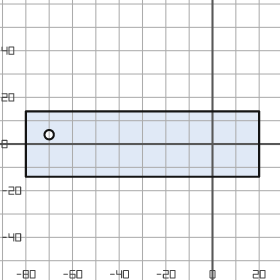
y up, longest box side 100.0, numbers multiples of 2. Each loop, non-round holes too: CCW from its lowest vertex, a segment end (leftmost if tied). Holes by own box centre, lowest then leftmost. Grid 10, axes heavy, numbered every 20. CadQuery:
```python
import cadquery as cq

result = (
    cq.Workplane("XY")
    .moveTo(-80.0, -14.0)
    .lineTo(20.0, -14.0)
    .lineTo(20.0, 14.0)
    .lineTo(-80.0, 14.0)
    .close()
    .moveTo(-70.0, 4.0)
    .circle(2.0)
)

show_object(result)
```